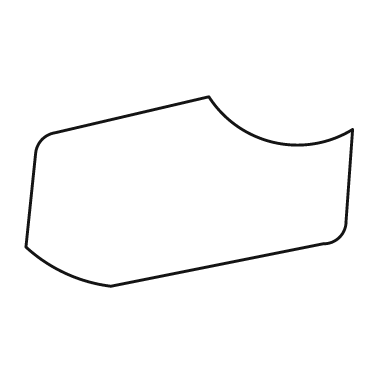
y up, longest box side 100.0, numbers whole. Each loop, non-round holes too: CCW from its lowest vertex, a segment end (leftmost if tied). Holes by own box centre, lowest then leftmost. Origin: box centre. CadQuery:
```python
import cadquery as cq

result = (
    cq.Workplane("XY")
    .moveTo(-24.0, -29.0)
    .lineTo(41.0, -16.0)
    .threePointArc((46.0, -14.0), (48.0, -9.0))
    .lineTo(50.0, 19.0)
    .threePointArc((26.0, 15.0), (6.0, 29.0))
    .lineTo(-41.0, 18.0)
    .threePointArc((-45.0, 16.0), (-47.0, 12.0))
    .lineTo(-50.0, -17.0)
    .threePointArc((-38.0, -25.0), (-24.0, -29.0))
    .close()
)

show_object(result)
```